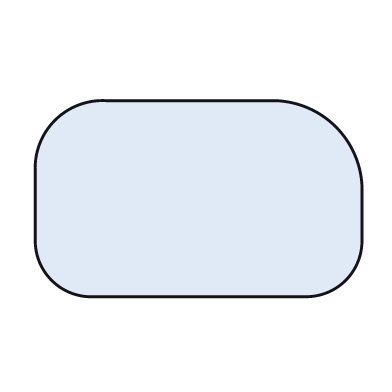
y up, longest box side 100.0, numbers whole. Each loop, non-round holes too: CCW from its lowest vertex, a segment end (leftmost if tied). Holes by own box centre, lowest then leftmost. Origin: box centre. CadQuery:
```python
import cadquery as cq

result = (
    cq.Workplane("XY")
    .moveTo(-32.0, -30.0)
    .lineTo(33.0, -30.0)
    .threePointArc((45.0, -25.0), (50.0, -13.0))
    .lineTo(50.0, 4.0)
    .threePointArc((42.0, 22.0), (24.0, 30.0))
    .lineTo(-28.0, 30.0)
    .threePointArc((-44.0, 24.0), (-50.0, 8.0))
    .lineTo(-50.0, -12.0)
    .threePointArc((-45.0, -25.0), (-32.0, -30.0))
    .close()
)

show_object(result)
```